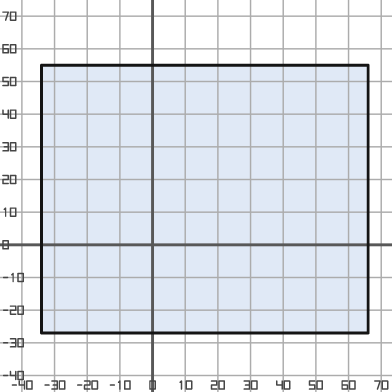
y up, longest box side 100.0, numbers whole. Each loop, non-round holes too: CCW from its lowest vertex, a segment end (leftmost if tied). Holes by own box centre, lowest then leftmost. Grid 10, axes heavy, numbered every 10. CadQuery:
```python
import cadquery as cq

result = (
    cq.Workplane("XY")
    .moveTo(-34.0, -27.0)
    .lineTo(66.0, -27.0)
    .lineTo(66.0, 55.0)
    .lineTo(-34.0, 55.0)
    .close()
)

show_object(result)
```